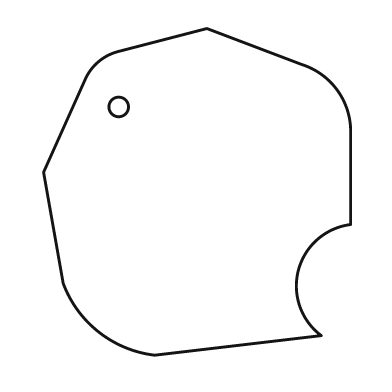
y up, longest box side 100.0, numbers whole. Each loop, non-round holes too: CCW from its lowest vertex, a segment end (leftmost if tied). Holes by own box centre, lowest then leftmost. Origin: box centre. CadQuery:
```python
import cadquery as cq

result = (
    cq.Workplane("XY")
    .moveTo(-13.0, -50.0)
    .lineTo(38.0, -44.0)
    .threePointArc((31.0, -24.0), (47.0, -10.0))
    .lineTo(47.0, 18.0)
    .threePointArc((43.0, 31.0), (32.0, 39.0))
    .lineTo(3.0, 50.0)
    .lineTo(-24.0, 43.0)
    .threePointArc((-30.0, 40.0), (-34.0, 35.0))
    .lineTo(-47.0, 6.0)
    .lineTo(-41.0, -28.0)
    .threePointArc((-30.0, -43.0), (-13.0, -50.0))
    .close()
    .moveTo(-24.0, 26.0)
    .circle(3.0)
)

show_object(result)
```